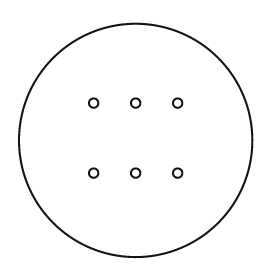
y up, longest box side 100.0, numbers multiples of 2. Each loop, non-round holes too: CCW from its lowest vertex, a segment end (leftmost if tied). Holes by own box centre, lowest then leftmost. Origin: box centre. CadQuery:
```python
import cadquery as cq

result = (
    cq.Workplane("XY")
    .moveTo(0.0, 0.0)
    .circle(50.0)
    .moveTo(-18.0, -14.0)
    .circle(2.0)
    .moveTo(0.0, -14.0)
    .circle(2.0)
    .moveTo(18.0, -14.0)
    .circle(2.0)
    .moveTo(-18.0, 16.0)
    .circle(2.0)
    .moveTo(0.0, 16.0)
    .circle(2.0)
    .moveTo(18.0, 16.0)
    .circle(2.0)
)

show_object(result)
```